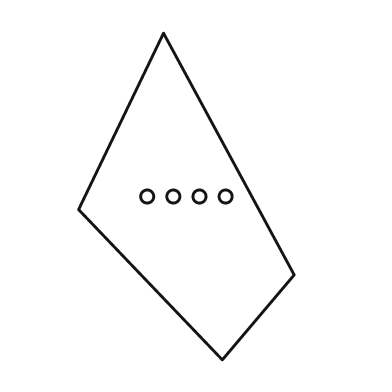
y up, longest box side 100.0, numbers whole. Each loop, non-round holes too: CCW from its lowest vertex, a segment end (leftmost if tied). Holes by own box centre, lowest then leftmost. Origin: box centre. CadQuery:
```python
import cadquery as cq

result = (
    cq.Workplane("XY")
    .moveTo(11.0, -50.0)
    .lineTo(33.0, -24.0)
    .lineTo(-7.0, 50.0)
    .lineTo(-33.0, -4.0)
    .close()
    .moveTo(-12.0, 0.0)
    .circle(2.0)
    .moveTo(-4.0, 0.0)
    .circle(2.0)
    .moveTo(4.0, 0.0)
    .circle(2.0)
    .moveTo(12.0, 0.0)
    .circle(2.0)
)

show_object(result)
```